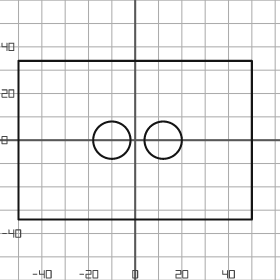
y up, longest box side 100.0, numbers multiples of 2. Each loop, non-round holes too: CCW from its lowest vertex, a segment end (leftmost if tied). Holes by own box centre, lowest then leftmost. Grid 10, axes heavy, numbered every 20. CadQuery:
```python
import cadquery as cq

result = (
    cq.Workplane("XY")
    .moveTo(-50.0, -34.0)
    .lineTo(50.0, -34.0)
    .lineTo(50.0, 34.0)
    .lineTo(-50.0, 34.0)
    .close()
    .moveTo(-10.0, 0.0)
    .circle(8.0)
    .moveTo(12.0, 0.0)
    .circle(8.0)
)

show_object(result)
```